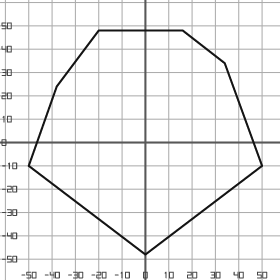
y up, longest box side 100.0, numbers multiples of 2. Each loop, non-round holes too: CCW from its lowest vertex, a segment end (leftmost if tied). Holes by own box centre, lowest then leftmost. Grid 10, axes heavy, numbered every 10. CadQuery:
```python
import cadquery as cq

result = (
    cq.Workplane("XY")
    .moveTo(0.0, -48.0)
    .lineTo(50.0, -10.0)
    .lineTo(34.0, 34.0)
    .lineTo(16.0, 48.0)
    .lineTo(-20.0, 48.0)
    .lineTo(-38.0, 24.0)
    .lineTo(-50.0, -10.0)
    .close()
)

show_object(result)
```